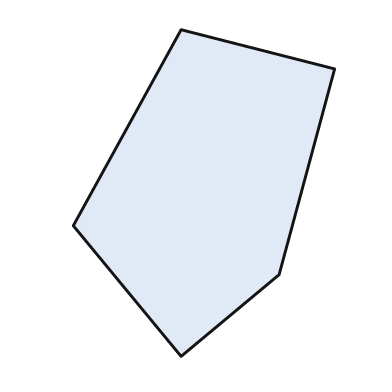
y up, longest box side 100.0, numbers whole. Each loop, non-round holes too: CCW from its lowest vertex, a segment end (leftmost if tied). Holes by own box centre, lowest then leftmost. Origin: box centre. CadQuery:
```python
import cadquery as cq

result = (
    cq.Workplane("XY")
    .moveTo(-7.0, -50.0)
    .lineTo(23.0, -25.0)
    .lineTo(40.0, 38.0)
    .lineTo(-7.0, 50.0)
    .lineTo(-40.0, -10.0)
    .close()
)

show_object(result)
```